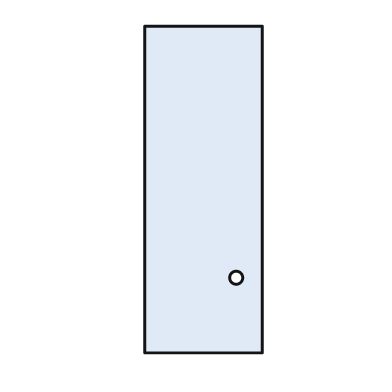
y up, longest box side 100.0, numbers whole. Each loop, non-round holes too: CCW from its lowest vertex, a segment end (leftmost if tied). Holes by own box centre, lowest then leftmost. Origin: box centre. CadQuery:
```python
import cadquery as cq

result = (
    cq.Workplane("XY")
    .moveTo(-18.0, -50.0)
    .lineTo(18.0, -50.0)
    .lineTo(18.0, 50.0)
    .lineTo(-18.0, 50.0)
    .close()
    .moveTo(10.0, -27.0)
    .circle(2.0)
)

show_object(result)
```